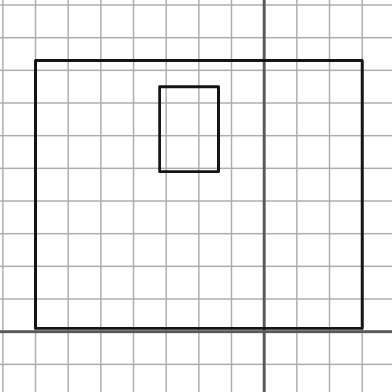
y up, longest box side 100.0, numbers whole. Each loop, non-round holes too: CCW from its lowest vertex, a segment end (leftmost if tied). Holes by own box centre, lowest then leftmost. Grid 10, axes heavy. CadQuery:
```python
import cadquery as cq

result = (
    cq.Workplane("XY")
    .moveTo(-70.0, 1.0)
    .lineTo(30.0, 1.0)
    .lineTo(30.0, 83.0)
    .lineTo(-70.0, 83.0)
    .close()
    .moveTo(-32.0, 49.0)
    .lineTo(-14.0, 49.0)
    .lineTo(-14.0, 75.0)
    .lineTo(-32.0, 75.0)
    .close()
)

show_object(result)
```